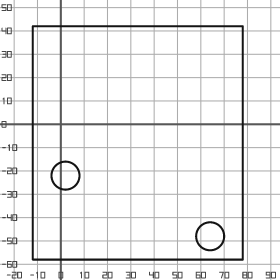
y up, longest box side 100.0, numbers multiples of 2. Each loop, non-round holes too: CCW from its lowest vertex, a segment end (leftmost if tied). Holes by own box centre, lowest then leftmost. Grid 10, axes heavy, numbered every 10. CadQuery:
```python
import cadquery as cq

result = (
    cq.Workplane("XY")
    .moveTo(-12.0, -58.0)
    .lineTo(78.0, -58.0)
    .lineTo(78.0, 42.0)
    .lineTo(-12.0, 42.0)
    .close()
    .moveTo(64.0, -48.0)
    .circle(6.0)
    .moveTo(2.0, -22.0)
    .circle(6.0)
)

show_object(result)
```